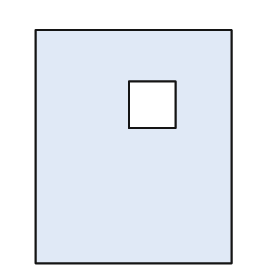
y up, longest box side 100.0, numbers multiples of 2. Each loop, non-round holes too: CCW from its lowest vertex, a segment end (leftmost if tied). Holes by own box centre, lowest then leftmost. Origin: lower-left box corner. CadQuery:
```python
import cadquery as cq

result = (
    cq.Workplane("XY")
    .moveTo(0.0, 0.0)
    .lineTo(84.0, 0.0)
    .lineTo(84.0, 100.0)
    .lineTo(0.0, 100.0)
    .close()
    .moveTo(40.0, 58.0)
    .lineTo(60.0, 58.0)
    .lineTo(60.0, 78.0)
    .lineTo(40.0, 78.0)
    .close()
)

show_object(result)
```